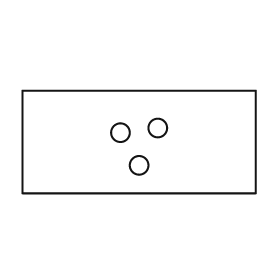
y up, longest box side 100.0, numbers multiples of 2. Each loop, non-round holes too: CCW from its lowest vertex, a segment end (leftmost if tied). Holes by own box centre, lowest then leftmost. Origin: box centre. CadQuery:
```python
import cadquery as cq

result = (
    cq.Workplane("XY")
    .moveTo(-50.0, -22.0)
    .lineTo(50.0, -22.0)
    .lineTo(50.0, 22.0)
    .lineTo(-50.0, 22.0)
    .close()
    .moveTo(0.0, -10.0)
    .circle(4.0)
    .moveTo(-8.0, 4.0)
    .circle(4.0)
    .moveTo(8.0, 6.0)
    .circle(4.0)
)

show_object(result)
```